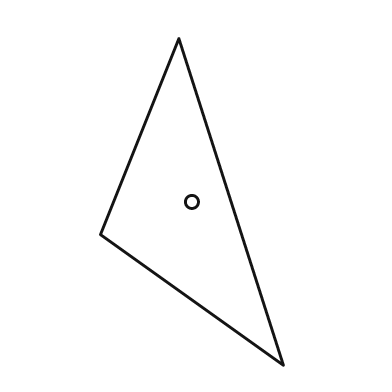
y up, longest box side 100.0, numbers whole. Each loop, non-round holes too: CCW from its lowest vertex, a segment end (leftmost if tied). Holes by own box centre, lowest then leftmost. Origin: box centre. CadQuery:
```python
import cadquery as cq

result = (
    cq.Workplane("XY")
    .moveTo(28.0, -50.0)
    .lineTo(-4.0, 50.0)
    .lineTo(-28.0, -10.0)
    .close()
    .moveTo(0.0, 0.0)
    .circle(2.0)
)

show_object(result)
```